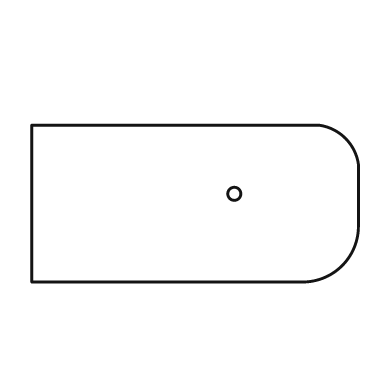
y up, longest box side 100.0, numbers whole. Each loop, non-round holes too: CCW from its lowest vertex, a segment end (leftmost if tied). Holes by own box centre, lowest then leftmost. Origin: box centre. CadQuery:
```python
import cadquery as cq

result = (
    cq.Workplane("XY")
    .moveTo(-50.0, -24.0)
    .lineTo(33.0, -24.0)
    .threePointArc((45.0, -19.0), (50.0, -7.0))
    .lineTo(50.0, 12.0)
    .threePointArc((46.0, 20.0), (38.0, 24.0))
    .lineTo(-50.0, 24.0)
    .close()
    .moveTo(12.0, 3.0)
    .circle(2.0)
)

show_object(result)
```